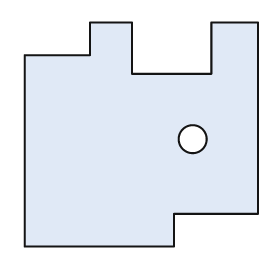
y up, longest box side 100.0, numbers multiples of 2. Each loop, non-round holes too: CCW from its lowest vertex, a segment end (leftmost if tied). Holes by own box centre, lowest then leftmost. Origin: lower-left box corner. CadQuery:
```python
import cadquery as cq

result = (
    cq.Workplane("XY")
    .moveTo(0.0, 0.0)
    .lineTo(64.0, 0.0)
    .lineTo(64.0, 14.0)
    .lineTo(100.0, 14.0)
    .lineTo(100.0, 96.0)
    .lineTo(80.0, 96.0)
    .lineTo(80.0, 74.0)
    .lineTo(46.0, 74.0)
    .lineTo(46.0, 96.0)
    .lineTo(28.0, 96.0)
    .lineTo(28.0, 82.0)
    .lineTo(0.0, 82.0)
    .close()
    .moveTo(72.0, 46.0)
    .circle(6.0)
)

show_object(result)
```